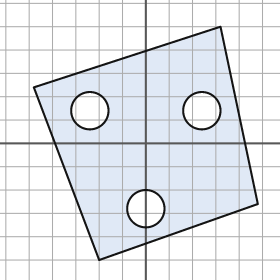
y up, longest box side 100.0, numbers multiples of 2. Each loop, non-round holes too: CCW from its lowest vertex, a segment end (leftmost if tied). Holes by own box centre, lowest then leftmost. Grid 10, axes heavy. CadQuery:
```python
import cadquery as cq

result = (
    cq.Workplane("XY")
    .moveTo(-20.0, -50.0)
    .lineTo(48.0, -26.0)
    .lineTo(32.0, 50.0)
    .lineTo(-48.0, 24.0)
    .close()
    .moveTo(0.0, -28.0)
    .circle(8.0)
    .moveTo(-24.0, 14.0)
    .circle(8.0)
    .moveTo(24.0, 14.0)
    .circle(8.0)
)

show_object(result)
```